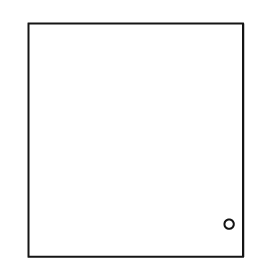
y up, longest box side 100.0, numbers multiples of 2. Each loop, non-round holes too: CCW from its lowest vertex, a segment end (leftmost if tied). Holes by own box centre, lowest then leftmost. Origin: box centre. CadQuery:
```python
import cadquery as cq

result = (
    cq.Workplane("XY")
    .moveTo(-46.0, -50.0)
    .lineTo(46.0, -50.0)
    .lineTo(46.0, 50.0)
    .lineTo(-46.0, 50.0)
    .close()
    .moveTo(40.0, -36.0)
    .circle(2.0)
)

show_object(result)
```